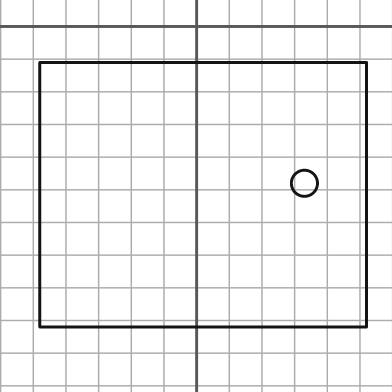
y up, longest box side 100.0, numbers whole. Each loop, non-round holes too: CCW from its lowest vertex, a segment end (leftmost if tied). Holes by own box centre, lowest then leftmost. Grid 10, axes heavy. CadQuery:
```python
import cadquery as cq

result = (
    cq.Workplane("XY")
    .moveTo(-48.0, -92.0)
    .lineTo(52.0, -92.0)
    .lineTo(52.0, -11.0)
    .lineTo(-48.0, -11.0)
    .close()
    .moveTo(33.0, -48.0)
    .circle(4.0)
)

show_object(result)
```